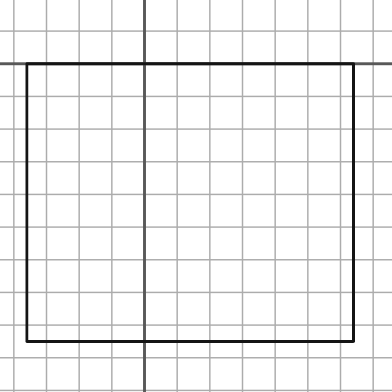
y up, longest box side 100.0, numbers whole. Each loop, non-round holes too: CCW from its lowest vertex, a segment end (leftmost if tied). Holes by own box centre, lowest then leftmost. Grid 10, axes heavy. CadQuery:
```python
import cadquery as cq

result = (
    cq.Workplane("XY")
    .moveTo(-36.0, -85.0)
    .lineTo(64.0, -85.0)
    .lineTo(64.0, 0.0)
    .lineTo(-36.0, 0.0)
    .close()
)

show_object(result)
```